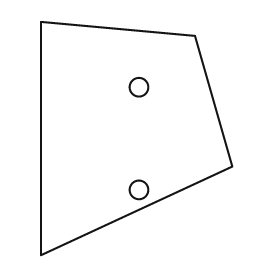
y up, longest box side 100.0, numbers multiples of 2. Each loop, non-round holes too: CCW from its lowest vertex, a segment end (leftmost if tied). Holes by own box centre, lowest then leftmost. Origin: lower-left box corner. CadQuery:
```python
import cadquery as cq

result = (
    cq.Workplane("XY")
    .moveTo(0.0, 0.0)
    .lineTo(82.0, 38.0)
    .lineTo(66.0, 94.0)
    .lineTo(0.0, 100.0)
    .close()
    .moveTo(42.0, 28.0)
    .circle(4.0)
    .moveTo(42.0, 72.0)
    .circle(4.0)
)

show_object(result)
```